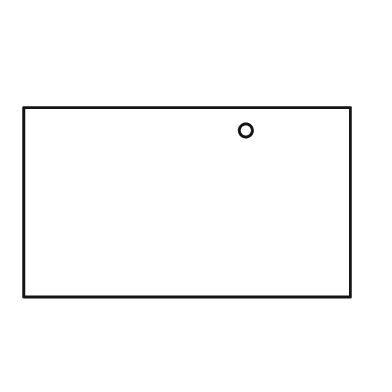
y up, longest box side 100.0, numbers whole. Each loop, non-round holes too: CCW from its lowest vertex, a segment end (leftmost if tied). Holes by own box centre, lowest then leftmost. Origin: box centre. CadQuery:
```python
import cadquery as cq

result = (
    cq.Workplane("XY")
    .moveTo(-50.0, -29.0)
    .lineTo(50.0, -29.0)
    .lineTo(50.0, 29.0)
    .lineTo(-50.0, 29.0)
    .close()
    .moveTo(18.0, 22.0)
    .circle(2.0)
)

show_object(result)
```